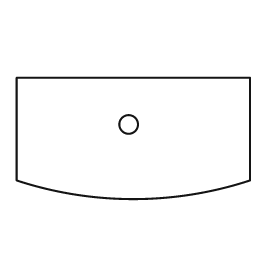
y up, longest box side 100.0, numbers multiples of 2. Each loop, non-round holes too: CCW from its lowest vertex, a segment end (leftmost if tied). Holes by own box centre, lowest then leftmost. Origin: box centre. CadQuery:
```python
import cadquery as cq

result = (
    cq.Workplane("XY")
    .moveTo(-50.0, -18.0)
    .threePointArc((0.0, -26.0), (50.0, -18.0))
    .lineTo(50.0, 26.0)
    .lineTo(-50.0, 26.0)
    .close()
    .moveTo(-2.0, 6.0)
    .circle(4.0)
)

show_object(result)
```